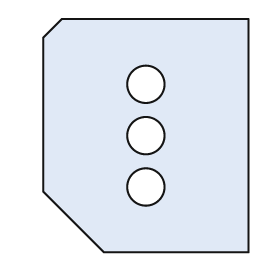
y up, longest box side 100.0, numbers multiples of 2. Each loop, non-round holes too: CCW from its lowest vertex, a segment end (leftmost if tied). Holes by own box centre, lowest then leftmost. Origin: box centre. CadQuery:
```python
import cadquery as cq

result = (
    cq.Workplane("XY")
    .moveTo(-18.0, -50.0)
    .lineTo(44.0, -50.0)
    .lineTo(44.0, 50.0)
    .lineTo(-36.0, 50.0)
    .lineTo(-44.0, 42.0)
    .lineTo(-44.0, -24.0)
    .close()
    .moveTo(0.0, -22.0)
    .circle(8.0)
    .moveTo(0.0, 0.0)
    .circle(8.0)
    .moveTo(0.0, 22.0)
    .circle(8.0)
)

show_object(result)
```